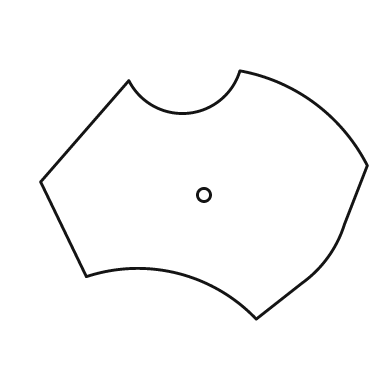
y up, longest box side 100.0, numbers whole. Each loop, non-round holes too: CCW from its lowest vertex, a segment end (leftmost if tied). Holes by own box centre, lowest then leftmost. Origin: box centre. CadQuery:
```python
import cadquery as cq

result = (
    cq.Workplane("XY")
    .moveTo(16.0, -38.0)
    .lineTo(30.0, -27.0)
    .threePointArc((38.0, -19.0), (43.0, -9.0))
    .lineTo(50.0, 9.0)
    .threePointArc((34.0, 28.0), (11.0, 38.0))
    .threePointArc((-5.0, 25.0), (-23.0, 35.0))
    .lineTo(-50.0, 4.0)
    .lineTo(-36.0, -25.0)
    .threePointArc((-8.0, -24.0), (16.0, -38.0))
    .close()
    .moveTo(0.0, 0.0)
    .circle(2.0)
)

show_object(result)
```